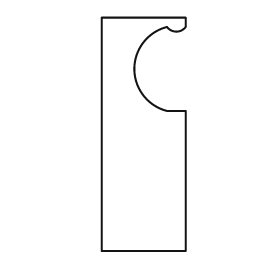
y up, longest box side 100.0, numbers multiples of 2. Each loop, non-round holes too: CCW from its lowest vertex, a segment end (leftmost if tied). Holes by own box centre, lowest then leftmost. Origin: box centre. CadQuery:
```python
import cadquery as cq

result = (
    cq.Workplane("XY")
    .moveTo(-18.0, -50.0)
    .lineTo(18.0, -50.0)
    .lineTo(18.0, 10.0)
    .lineTo(10.0, 10.0)
    .threePointArc((-4.0, 28.0), (10.0, 46.0))
    .threePointArc((14.0, 44.0), (18.0, 46.0))
    .lineTo(18.0, 50.0)
    .lineTo(-18.0, 50.0)
    .close()
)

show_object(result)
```